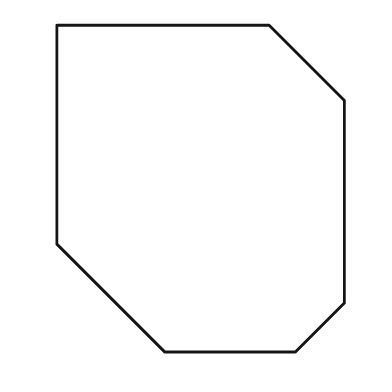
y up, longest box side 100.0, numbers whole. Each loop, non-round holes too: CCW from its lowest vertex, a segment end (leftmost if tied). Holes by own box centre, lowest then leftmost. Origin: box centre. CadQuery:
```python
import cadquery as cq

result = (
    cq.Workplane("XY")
    .moveTo(-11.0, -50.0)
    .lineTo(29.0, -50.0)
    .lineTo(44.0, -35.0)
    .lineTo(44.0, 27.0)
    .lineTo(21.0, 50.0)
    .lineTo(-44.0, 50.0)
    .lineTo(-44.0, -17.0)
    .close()
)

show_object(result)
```